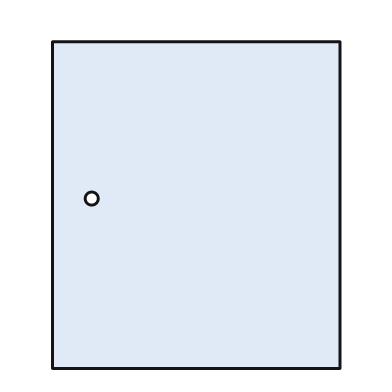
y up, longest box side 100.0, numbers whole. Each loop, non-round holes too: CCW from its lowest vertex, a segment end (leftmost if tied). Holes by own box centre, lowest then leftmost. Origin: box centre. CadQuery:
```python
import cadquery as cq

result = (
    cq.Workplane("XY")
    .moveTo(-44.0, -50.0)
    .lineTo(44.0, -50.0)
    .lineTo(44.0, 50.0)
    .lineTo(-44.0, 50.0)
    .close()
    .moveTo(-32.0, 2.0)
    .circle(2.0)
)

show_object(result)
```